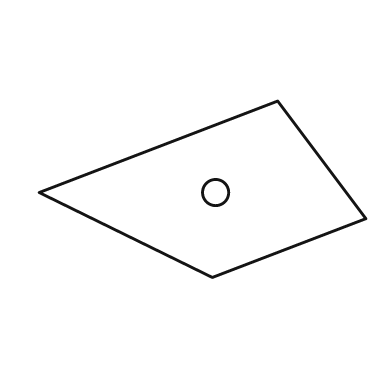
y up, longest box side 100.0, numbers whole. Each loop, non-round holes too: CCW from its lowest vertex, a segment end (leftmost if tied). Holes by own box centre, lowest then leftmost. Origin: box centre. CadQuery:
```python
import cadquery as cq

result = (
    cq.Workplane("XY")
    .moveTo(3.0, -27.0)
    .lineTo(50.0, -9.0)
    .lineTo(23.0, 27.0)
    .lineTo(-50.0, -1.0)
    .close()
    .moveTo(4.0, -1.0)
    .circle(4.0)
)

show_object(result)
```